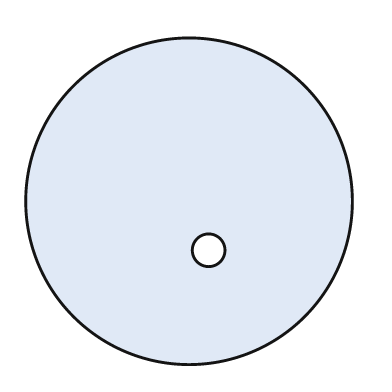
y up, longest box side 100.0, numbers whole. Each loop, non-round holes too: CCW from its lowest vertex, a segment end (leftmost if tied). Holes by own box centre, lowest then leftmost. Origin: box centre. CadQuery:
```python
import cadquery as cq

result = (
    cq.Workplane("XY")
    .moveTo(0.0, 0.0)
    .circle(50.0)
    .moveTo(6.0, -15.0)
    .circle(5.0)
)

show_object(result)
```